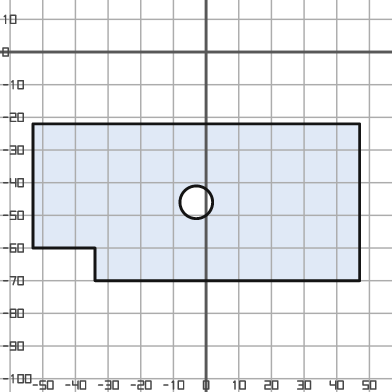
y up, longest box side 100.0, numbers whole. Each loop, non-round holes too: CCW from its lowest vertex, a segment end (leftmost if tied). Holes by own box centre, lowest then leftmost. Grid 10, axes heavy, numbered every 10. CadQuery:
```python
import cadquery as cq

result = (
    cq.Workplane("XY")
    .moveTo(-34.0, -70.0)
    .lineTo(47.0, -70.0)
    .lineTo(47.0, -22.0)
    .lineTo(-53.0, -22.0)
    .lineTo(-53.0, -60.0)
    .lineTo(-34.0, -60.0)
    .close()
    .moveTo(-3.0, -46.0)
    .circle(5.0)
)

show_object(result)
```